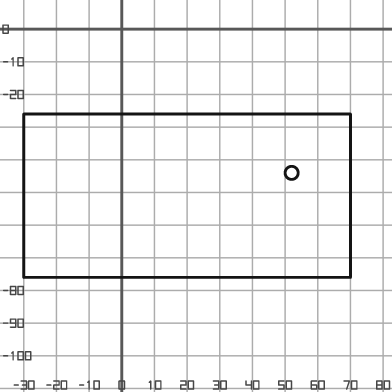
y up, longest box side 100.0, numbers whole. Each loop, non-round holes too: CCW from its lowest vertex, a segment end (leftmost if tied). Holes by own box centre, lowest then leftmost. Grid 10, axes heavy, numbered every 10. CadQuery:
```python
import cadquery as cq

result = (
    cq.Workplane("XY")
    .moveTo(-30.0, -76.0)
    .lineTo(70.0, -76.0)
    .lineTo(70.0, -26.0)
    .lineTo(-30.0, -26.0)
    .close()
    .moveTo(52.0, -44.0)
    .circle(2.0)
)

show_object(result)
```